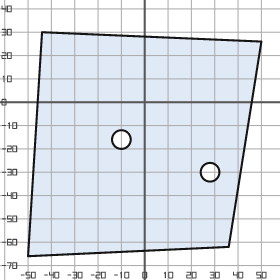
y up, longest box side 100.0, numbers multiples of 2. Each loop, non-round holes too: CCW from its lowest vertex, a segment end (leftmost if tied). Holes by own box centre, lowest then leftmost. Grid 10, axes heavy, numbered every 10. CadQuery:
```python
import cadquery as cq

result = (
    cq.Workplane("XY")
    .moveTo(-50.0, -66.0)
    .lineTo(36.0, -62.0)
    .lineTo(50.0, 26.0)
    .lineTo(-44.0, 30.0)
    .close()
    .moveTo(28.0, -30.0)
    .circle(4.0)
    .moveTo(-10.0, -16.0)
    .circle(4.0)
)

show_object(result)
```